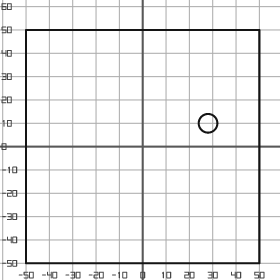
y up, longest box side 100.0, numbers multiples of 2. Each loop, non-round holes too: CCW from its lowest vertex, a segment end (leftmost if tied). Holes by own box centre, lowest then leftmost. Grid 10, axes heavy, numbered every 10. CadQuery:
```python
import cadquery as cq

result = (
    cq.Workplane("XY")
    .moveTo(-50.0, -50.0)
    .lineTo(50.0, -50.0)
    .lineTo(50.0, 50.0)
    .lineTo(-50.0, 50.0)
    .close()
    .moveTo(28.0, 10.0)
    .circle(4.0)
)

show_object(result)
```